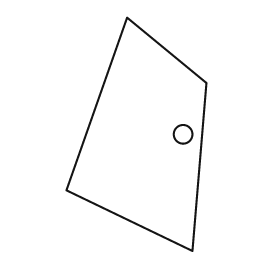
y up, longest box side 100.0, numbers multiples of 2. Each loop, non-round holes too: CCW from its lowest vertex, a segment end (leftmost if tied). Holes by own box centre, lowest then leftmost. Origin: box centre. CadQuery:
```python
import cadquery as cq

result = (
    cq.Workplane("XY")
    .moveTo(24.0, -50.0)
    .lineTo(30.0, 22.0)
    .lineTo(-4.0, 50.0)
    .lineTo(-30.0, -24.0)
    .close()
    .moveTo(20.0, 0.0)
    .circle(4.0)
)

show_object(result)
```